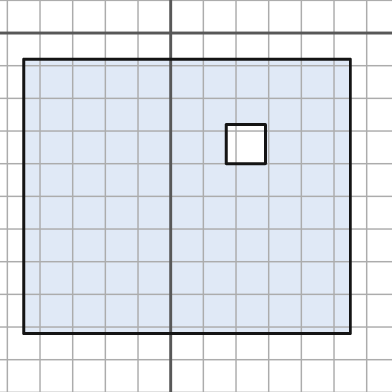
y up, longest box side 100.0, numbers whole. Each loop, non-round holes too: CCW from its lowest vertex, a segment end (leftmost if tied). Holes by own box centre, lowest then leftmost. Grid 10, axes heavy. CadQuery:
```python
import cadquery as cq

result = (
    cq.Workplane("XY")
    .moveTo(-45.0, -92.0)
    .lineTo(55.0, -92.0)
    .lineTo(55.0, -8.0)
    .lineTo(-45.0, -8.0)
    .close()
    .moveTo(17.0, -40.0)
    .lineTo(29.0, -40.0)
    .lineTo(29.0, -28.0)
    .lineTo(17.0, -28.0)
    .close()
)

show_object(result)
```